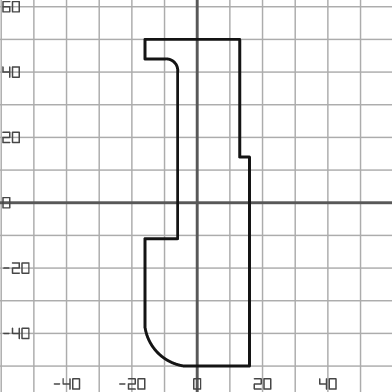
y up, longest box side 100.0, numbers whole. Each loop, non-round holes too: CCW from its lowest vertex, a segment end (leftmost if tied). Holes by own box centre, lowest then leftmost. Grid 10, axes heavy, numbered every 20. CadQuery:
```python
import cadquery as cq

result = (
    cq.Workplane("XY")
    .moveTo(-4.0, -50.0)
    .lineTo(16.0, -50.0)
    .lineTo(16.0, 14.0)
    .lineTo(13.0, 14.0)
    .lineTo(13.0, 50.0)
    .lineTo(-16.0, 50.0)
    .lineTo(-16.0, 44.0)
    .lineTo(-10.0, 44.0)
    .threePointArc((-7.0, 43.0), (-6.0, 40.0))
    .lineTo(-6.0, -11.0)
    .lineTo(-16.0, -11.0)
    .lineTo(-16.0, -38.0)
    .threePointArc((-12.0, -46.0), (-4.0, -50.0))
    .close()
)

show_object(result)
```